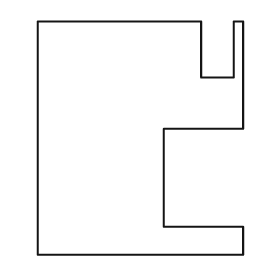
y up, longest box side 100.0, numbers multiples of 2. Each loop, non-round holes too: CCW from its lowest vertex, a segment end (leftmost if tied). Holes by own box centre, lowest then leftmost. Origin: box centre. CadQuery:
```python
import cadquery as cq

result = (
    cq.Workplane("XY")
    .moveTo(-44.0, -50.0)
    .lineTo(44.0, -50.0)
    .lineTo(44.0, -38.0)
    .lineTo(10.0, -38.0)
    .lineTo(10.0, 4.0)
    .lineTo(44.0, 4.0)
    .lineTo(44.0, 50.0)
    .lineTo(40.0, 50.0)
    .lineTo(40.0, 26.0)
    .lineTo(26.0, 26.0)
    .lineTo(26.0, 50.0)
    .lineTo(-44.0, 50.0)
    .close()
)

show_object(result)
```